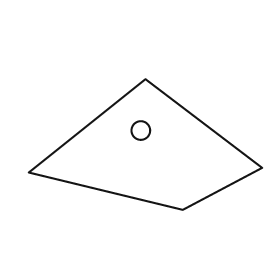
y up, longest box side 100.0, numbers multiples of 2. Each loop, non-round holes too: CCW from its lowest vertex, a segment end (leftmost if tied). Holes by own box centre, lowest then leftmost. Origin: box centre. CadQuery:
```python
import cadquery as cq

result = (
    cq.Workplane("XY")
    .moveTo(16.0, -28.0)
    .lineTo(50.0, -10.0)
    .lineTo(0.0, 28.0)
    .lineTo(-50.0, -12.0)
    .close()
    .moveTo(-2.0, 6.0)
    .circle(4.0)
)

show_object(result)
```